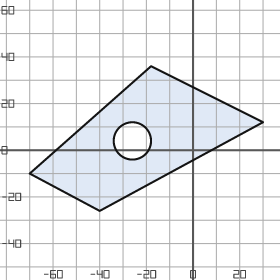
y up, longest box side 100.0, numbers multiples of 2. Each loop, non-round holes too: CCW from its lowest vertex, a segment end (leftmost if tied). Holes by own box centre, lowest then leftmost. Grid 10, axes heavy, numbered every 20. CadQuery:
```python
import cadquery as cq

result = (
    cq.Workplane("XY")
    .moveTo(-40.0, -26.0)
    .lineTo(30.0, 12.0)
    .lineTo(-18.0, 36.0)
    .lineTo(-70.0, -10.0)
    .close()
    .moveTo(-26.0, 4.0)
    .circle(8.0)
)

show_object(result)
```